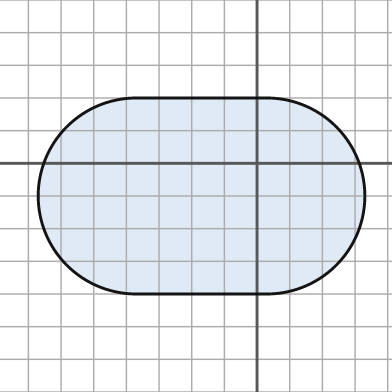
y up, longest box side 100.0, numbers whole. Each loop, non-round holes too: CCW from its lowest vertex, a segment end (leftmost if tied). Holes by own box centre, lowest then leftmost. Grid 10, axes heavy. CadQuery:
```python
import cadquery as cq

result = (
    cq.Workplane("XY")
    .moveTo(-37.0, -40.0)
    .lineTo(3.0, -40.0)
    .threePointArc((33.0, -10.0), (3.0, 20.0))
    .lineTo(-37.0, 20.0)
    .threePointArc((-67.0, -10.0), (-37.0, -40.0))
    .close()
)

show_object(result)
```